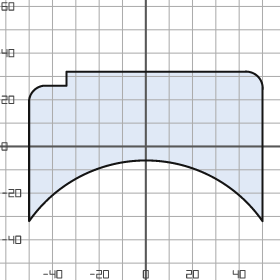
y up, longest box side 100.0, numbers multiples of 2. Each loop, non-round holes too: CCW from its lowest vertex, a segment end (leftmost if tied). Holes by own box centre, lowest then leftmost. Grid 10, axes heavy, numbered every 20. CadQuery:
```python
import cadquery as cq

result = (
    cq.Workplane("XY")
    .moveTo(-50.0, -32.0)
    .threePointArc((0.0, -6.0), (50.0, -32.0))
    .lineTo(50.0, 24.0)
    .threePointArc((48.0, 30.0), (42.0, 32.0))
    .lineTo(-34.0, 32.0)
    .lineTo(-34.0, 26.0)
    .lineTo(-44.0, 26.0)
    .threePointArc((-48.0, 24.0), (-50.0, 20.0))
    .close()
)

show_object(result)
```